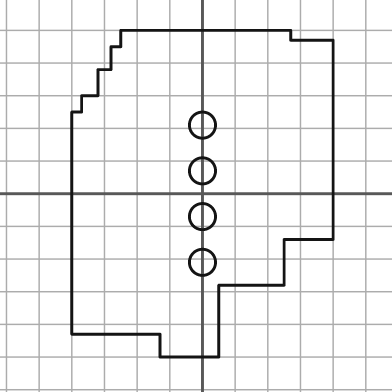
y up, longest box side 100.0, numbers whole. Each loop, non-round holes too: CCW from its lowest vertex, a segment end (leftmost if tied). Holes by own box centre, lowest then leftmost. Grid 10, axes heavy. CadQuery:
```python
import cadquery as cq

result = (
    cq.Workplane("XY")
    .moveTo(-13.0, -50.0)
    .lineTo(5.0, -50.0)
    .lineTo(5.0, -28.0)
    .lineTo(25.0, -28.0)
    .lineTo(25.0, -14.0)
    .lineTo(40.0, -14.0)
    .lineTo(40.0, 47.0)
    .lineTo(27.0, 47.0)
    .lineTo(27.0, 50.0)
    .lineTo(-25.0, 50.0)
    .lineTo(-25.0, 45.0)
    .lineTo(-28.0, 45.0)
    .lineTo(-28.0, 38.0)
    .lineTo(-32.0, 38.0)
    .lineTo(-32.0, 30.0)
    .lineTo(-37.0, 30.0)
    .lineTo(-37.0, 25.0)
    .lineTo(-40.0, 25.0)
    .lineTo(-40.0, -43.0)
    .lineTo(-13.0, -43.0)
    .close()
    .moveTo(0.0, -21.0)
    .circle(4.0)
    .moveTo(0.0, -7.0)
    .circle(4.0)
    .moveTo(0.0, 7.0)
    .circle(4.0)
    .moveTo(0.0, 21.0)
    .circle(4.0)
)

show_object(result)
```